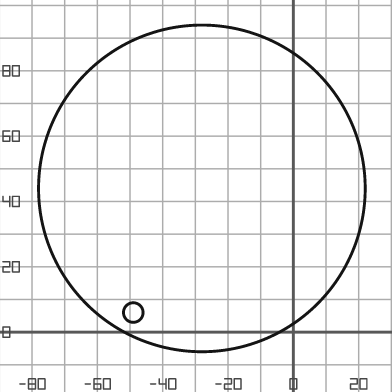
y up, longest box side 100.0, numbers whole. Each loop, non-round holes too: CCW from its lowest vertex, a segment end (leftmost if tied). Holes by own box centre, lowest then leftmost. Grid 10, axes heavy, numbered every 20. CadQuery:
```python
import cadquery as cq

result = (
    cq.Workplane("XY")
    .moveTo(-28.0, 44.0)
    .circle(50.0)
    .moveTo(-49.0, 6.0)
    .circle(3.0)
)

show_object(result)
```